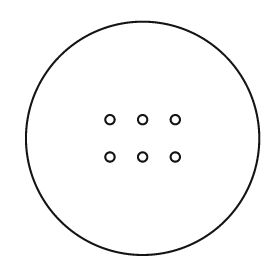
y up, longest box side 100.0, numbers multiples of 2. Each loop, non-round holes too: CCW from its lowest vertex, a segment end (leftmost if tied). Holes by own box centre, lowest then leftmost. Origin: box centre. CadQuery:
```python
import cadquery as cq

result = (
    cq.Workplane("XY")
    .moveTo(0.0, 0.0)
    .circle(50.0)
    .moveTo(-14.0, -8.0)
    .circle(2.0)
    .moveTo(0.0, -8.0)
    .circle(2.0)
    .moveTo(14.0, -8.0)
    .circle(2.0)
    .moveTo(-14.0, 8.0)
    .circle(2.0)
    .moveTo(0.0, 8.0)
    .circle(2.0)
    .moveTo(14.0, 8.0)
    .circle(2.0)
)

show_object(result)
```